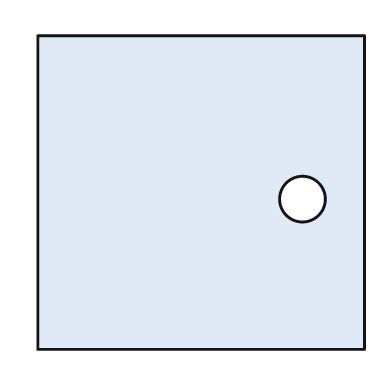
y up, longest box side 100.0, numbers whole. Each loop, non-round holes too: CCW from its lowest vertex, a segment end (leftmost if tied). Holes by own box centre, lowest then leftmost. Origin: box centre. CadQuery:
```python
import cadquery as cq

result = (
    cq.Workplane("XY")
    .moveTo(-50.0, -48.0)
    .lineTo(50.0, -48.0)
    .lineTo(50.0, 48.0)
    .lineTo(-50.0, 48.0)
    .close()
    .moveTo(31.0, -2.0)
    .circle(7.0)
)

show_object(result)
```